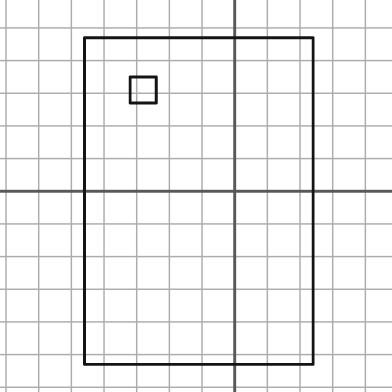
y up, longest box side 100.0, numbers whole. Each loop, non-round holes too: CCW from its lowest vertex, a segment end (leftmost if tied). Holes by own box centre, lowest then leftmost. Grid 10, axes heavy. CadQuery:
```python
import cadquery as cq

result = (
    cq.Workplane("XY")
    .moveTo(-46.0, -53.0)
    .lineTo(24.0, -53.0)
    .lineTo(24.0, 47.0)
    .lineTo(-46.0, 47.0)
    .close()
    .moveTo(-32.0, 27.0)
    .lineTo(-24.0, 27.0)
    .lineTo(-24.0, 35.0)
    .lineTo(-32.0, 35.0)
    .close()
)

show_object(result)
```